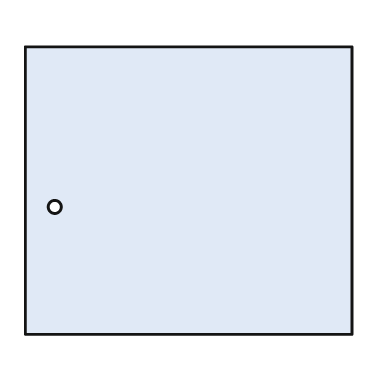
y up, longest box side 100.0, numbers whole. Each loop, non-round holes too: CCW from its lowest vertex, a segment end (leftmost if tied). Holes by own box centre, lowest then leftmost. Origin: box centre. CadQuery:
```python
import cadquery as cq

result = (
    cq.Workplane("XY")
    .moveTo(-50.0, -44.0)
    .lineTo(50.0, -44.0)
    .lineTo(50.0, 44.0)
    .lineTo(-50.0, 44.0)
    .close()
    .moveTo(-41.0, -5.0)
    .circle(2.0)
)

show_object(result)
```